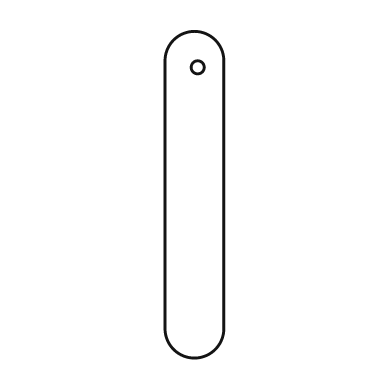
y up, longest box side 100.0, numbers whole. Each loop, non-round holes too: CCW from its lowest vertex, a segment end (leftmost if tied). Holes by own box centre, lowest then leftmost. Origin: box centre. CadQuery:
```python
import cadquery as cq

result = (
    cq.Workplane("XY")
    .moveTo(-9.0, -41.0)
    .threePointArc((0.0, -50.0), (9.0, -41.0))
    .lineTo(9.0, 41.0)
    .threePointArc((0.0, 50.0), (-9.0, 41.0))
    .close()
    .moveTo(1.0, 39.0)
    .circle(2.0)
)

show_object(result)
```